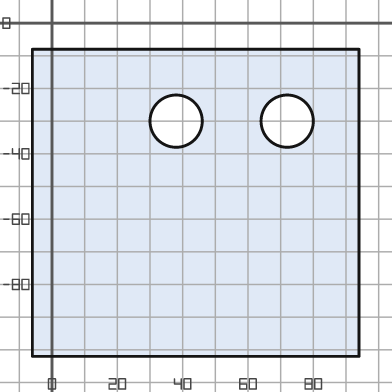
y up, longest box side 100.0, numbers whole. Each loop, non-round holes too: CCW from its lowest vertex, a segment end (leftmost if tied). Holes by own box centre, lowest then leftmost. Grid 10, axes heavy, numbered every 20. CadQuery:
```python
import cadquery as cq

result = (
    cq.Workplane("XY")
    .moveTo(-6.0, -102.0)
    .lineTo(94.0, -102.0)
    .lineTo(94.0, -8.0)
    .lineTo(-6.0, -8.0)
    .close()
    .moveTo(38.0, -30.0)
    .circle(8.0)
    .moveTo(72.0, -30.0)
    .circle(8.0)
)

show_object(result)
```